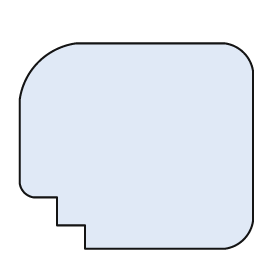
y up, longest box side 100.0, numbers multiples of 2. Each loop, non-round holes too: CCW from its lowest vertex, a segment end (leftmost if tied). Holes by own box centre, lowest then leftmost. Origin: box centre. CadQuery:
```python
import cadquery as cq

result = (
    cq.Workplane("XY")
    .moveTo(-22.0, -44.0)
    .lineTo(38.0, -44.0)
    .threePointArc((46.0, -40.0), (50.0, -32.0))
    .lineTo(50.0, 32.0)
    .threePointArc((46.0, 40.0), (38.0, 44.0))
    .lineTo(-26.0, 44.0)
    .threePointArc((-42.0, 36.0), (-50.0, 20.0))
    .lineTo(-50.0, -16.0)
    .threePointArc((-48.0, -20.0), (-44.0, -22.0))
    .lineTo(-34.0, -22.0)
    .lineTo(-34.0, -34.0)
    .lineTo(-22.0, -34.0)
    .close()
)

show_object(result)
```